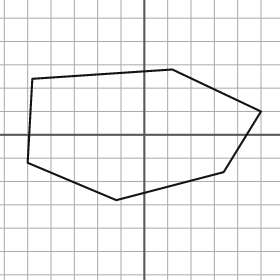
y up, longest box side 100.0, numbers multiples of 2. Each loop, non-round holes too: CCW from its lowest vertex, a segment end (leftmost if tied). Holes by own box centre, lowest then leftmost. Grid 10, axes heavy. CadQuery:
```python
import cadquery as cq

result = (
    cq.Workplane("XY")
    .moveTo(-12.0, -28.0)
    .lineTo(34.0, -16.0)
    .lineTo(50.0, 10.0)
    .lineTo(12.0, 28.0)
    .lineTo(-48.0, 24.0)
    .lineTo(-50.0, -12.0)
    .close()
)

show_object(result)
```